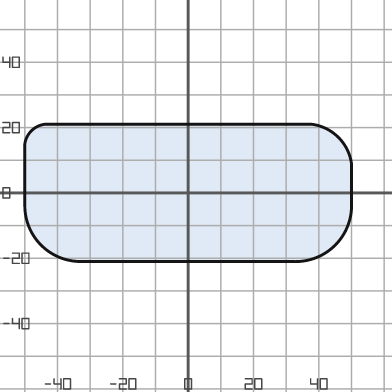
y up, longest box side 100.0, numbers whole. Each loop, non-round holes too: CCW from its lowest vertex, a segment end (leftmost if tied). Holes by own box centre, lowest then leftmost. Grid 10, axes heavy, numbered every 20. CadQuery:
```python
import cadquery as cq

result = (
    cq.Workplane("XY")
    .moveTo(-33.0, -21.0)
    .lineTo(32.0, -21.0)
    .threePointArc((45.0, -16.0), (50.0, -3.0))
    .lineTo(50.0, 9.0)
    .threePointArc((46.0, 17.0), (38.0, 21.0))
    .lineTo(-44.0, 21.0)
    .threePointArc((-48.0, 19.0), (-50.0, 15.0))
    .lineTo(-50.0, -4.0)
    .threePointArc((-45.0, -16.0), (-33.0, -21.0))
    .close()
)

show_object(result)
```